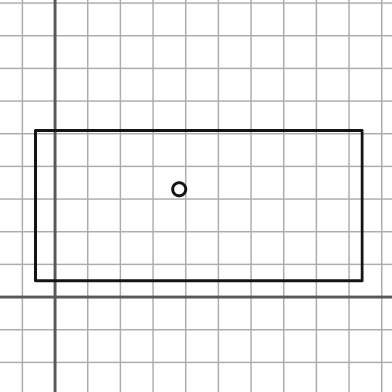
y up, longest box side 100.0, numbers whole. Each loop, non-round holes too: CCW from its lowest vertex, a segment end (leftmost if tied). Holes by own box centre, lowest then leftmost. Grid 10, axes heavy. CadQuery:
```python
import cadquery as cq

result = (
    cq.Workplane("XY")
    .moveTo(-6.0, 5.0)
    .lineTo(94.0, 5.0)
    .lineTo(94.0, 51.0)
    .lineTo(-6.0, 51.0)
    .close()
    .moveTo(38.0, 33.0)
    .circle(2.0)
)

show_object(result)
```